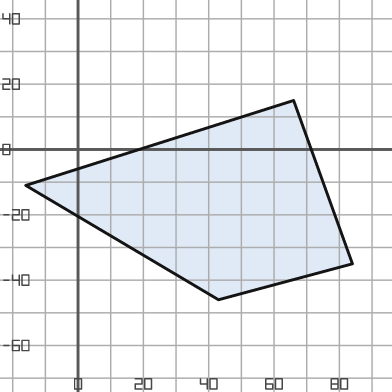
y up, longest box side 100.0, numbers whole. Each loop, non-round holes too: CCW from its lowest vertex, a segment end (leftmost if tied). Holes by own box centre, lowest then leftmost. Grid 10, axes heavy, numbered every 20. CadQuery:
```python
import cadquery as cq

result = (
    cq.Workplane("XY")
    .moveTo(43.0, -46.0)
    .lineTo(84.0, -35.0)
    .lineTo(66.0, 15.0)
    .lineTo(-16.0, -11.0)
    .close()
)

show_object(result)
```